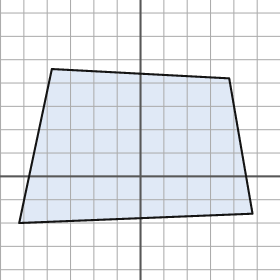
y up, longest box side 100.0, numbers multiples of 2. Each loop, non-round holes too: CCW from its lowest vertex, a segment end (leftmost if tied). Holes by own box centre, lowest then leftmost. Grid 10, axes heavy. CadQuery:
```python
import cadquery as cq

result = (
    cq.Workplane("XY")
    .moveTo(-52.0, -20.0)
    .lineTo(48.0, -16.0)
    .lineTo(38.0, 42.0)
    .lineTo(-38.0, 46.0)
    .close()
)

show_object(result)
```